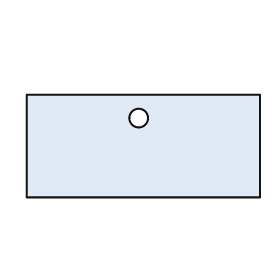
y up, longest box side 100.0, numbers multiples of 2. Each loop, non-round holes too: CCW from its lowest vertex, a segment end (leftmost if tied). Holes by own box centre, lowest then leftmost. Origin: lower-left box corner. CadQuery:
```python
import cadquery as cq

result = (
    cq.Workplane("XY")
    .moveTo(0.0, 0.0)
    .lineTo(100.0, 0.0)
    .lineTo(100.0, 44.0)
    .lineTo(0.0, 44.0)
    .close()
    .moveTo(48.0, 34.0)
    .circle(4.0)
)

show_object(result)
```